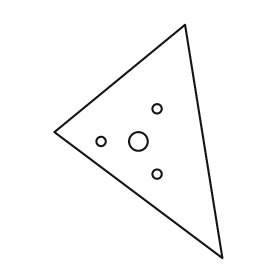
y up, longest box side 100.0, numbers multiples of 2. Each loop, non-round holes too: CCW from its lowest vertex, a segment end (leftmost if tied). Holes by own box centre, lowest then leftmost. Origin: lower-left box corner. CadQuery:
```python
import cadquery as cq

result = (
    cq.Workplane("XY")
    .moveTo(72.0, 0.0)
    .lineTo(56.0, 100.0)
    .lineTo(0.0, 54.0)
    .close()
    .moveTo(44.0, 36.0)
    .circle(2.0)
    .moveTo(20.0, 50.0)
    .circle(2.0)
    .moveTo(36.0, 50.0)
    .circle(4.0)
    .moveTo(44.0, 64.0)
    .circle(2.0)
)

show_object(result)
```